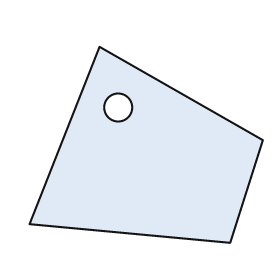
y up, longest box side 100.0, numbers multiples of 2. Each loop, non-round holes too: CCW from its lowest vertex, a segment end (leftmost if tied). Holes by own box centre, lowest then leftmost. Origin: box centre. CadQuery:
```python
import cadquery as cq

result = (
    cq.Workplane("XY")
    .moveTo(36.0, -42.0)
    .lineTo(50.0, 2.0)
    .lineTo(-20.0, 42.0)
    .lineTo(-50.0, -34.0)
    .close()
    .moveTo(-12.0, 16.0)
    .circle(6.0)
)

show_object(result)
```